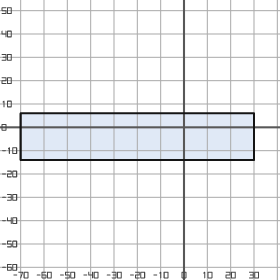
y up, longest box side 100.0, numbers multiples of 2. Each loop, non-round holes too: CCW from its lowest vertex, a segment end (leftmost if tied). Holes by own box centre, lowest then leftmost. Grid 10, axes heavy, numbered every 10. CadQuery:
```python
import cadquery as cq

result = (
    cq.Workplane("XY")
    .moveTo(-70.0, -14.0)
    .lineTo(30.0, -14.0)
    .lineTo(30.0, 6.0)
    .lineTo(-70.0, 6.0)
    .close()
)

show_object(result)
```